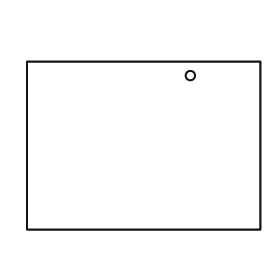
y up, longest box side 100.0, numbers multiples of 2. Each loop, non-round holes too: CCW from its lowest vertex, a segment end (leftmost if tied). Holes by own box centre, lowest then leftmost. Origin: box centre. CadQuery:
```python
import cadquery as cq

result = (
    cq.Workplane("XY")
    .moveTo(-50.0, -36.0)
    .lineTo(50.0, -36.0)
    .lineTo(50.0, 36.0)
    .lineTo(-50.0, 36.0)
    .close()
    .moveTo(20.0, 30.0)
    .circle(2.0)
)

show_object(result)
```